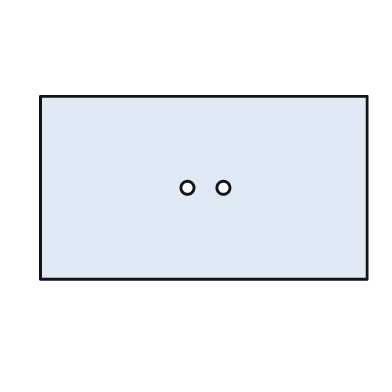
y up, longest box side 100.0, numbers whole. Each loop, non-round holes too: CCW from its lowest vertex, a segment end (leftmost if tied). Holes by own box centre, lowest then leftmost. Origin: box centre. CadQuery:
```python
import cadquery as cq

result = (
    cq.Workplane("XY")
    .moveTo(-50.0, -28.0)
    .lineTo(50.0, -28.0)
    .lineTo(50.0, 28.0)
    .lineTo(-50.0, 28.0)
    .close()
    .moveTo(-5.0, 0.0)
    .circle(2.0)
    .moveTo(6.0, 0.0)
    .circle(2.0)
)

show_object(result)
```